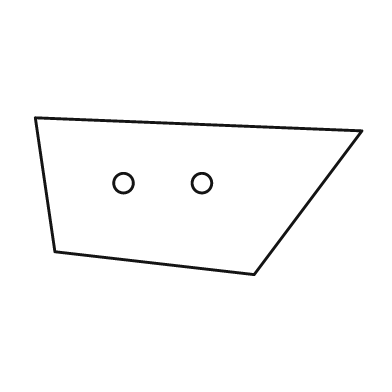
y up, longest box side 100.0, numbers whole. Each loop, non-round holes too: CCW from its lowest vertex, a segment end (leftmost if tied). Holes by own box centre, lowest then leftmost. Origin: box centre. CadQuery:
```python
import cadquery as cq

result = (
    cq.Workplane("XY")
    .moveTo(17.0, -24.0)
    .lineTo(50.0, 20.0)
    .lineTo(-50.0, 24.0)
    .lineTo(-44.0, -17.0)
    .close()
    .moveTo(-23.0, 4.0)
    .circle(3.0)
    .moveTo(1.0, 4.0)
    .circle(3.0)
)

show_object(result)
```